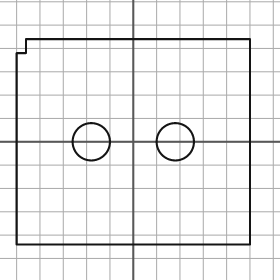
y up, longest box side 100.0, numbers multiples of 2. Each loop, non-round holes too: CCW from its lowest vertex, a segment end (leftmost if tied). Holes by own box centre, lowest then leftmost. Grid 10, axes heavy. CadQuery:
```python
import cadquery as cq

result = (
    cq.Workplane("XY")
    .moveTo(-50.0, -44.0)
    .lineTo(50.0, -44.0)
    .lineTo(50.0, 44.0)
    .lineTo(-46.0, 44.0)
    .lineTo(-46.0, 38.0)
    .lineTo(-50.0, 38.0)
    .close()
    .moveTo(-18.0, 0.0)
    .circle(8.0)
    .moveTo(18.0, 0.0)
    .circle(8.0)
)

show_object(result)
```